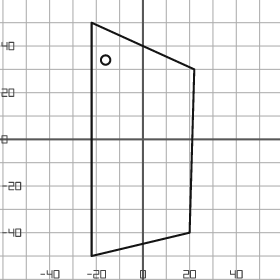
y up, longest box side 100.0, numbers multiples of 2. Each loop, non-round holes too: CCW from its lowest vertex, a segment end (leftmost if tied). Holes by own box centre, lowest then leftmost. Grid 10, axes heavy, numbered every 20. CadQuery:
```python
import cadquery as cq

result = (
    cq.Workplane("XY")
    .moveTo(-22.0, -50.0)
    .lineTo(20.0, -40.0)
    .lineTo(22.0, 30.0)
    .lineTo(-22.0, 50.0)
    .close()
    .moveTo(-16.0, 34.0)
    .circle(2.0)
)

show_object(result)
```